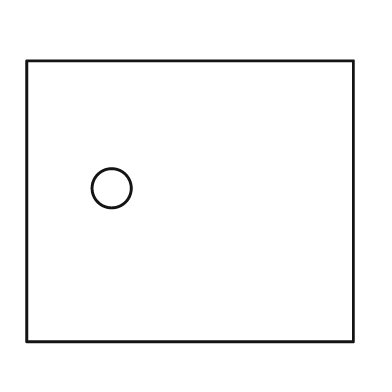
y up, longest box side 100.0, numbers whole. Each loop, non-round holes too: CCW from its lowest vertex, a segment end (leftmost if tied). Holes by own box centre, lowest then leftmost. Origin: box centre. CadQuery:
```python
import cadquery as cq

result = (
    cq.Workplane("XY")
    .moveTo(-50.0, -43.0)
    .lineTo(50.0, -43.0)
    .lineTo(50.0, 43.0)
    .lineTo(-50.0, 43.0)
    .close()
    .moveTo(-24.0, 4.0)
    .circle(6.0)
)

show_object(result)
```